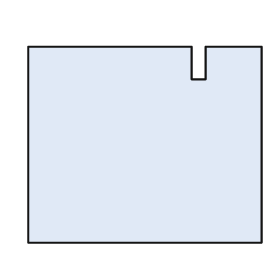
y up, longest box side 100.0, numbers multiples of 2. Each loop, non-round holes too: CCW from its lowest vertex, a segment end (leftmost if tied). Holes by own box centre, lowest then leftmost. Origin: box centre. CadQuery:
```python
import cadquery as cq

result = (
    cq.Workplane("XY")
    .moveTo(-50.0, -42.0)
    .lineTo(50.0, -42.0)
    .lineTo(50.0, 42.0)
    .lineTo(26.0, 42.0)
    .lineTo(26.0, 28.0)
    .lineTo(20.0, 28.0)
    .lineTo(20.0, 42.0)
    .lineTo(-50.0, 42.0)
    .close()
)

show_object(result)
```